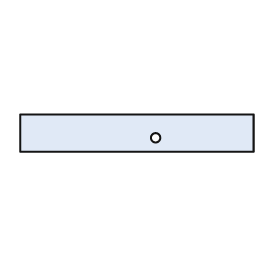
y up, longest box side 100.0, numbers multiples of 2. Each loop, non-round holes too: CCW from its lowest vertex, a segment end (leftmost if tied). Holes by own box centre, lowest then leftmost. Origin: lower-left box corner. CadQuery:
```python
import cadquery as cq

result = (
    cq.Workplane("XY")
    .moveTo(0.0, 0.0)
    .lineTo(100.0, 0.0)
    .lineTo(100.0, 16.0)
    .lineTo(0.0, 16.0)
    .close()
    .moveTo(58.0, 6.0)
    .circle(2.0)
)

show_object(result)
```